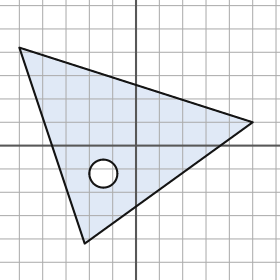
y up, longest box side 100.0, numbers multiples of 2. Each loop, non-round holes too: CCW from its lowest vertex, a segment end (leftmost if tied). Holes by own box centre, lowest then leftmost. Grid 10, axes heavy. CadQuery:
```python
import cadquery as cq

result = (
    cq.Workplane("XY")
    .moveTo(-22.0, -42.0)
    .lineTo(50.0, 10.0)
    .lineTo(-50.0, 42.0)
    .close()
    .moveTo(-14.0, -12.0)
    .circle(6.0)
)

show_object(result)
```